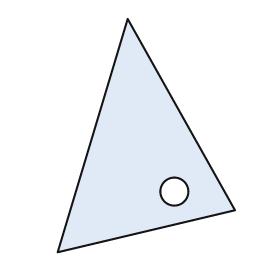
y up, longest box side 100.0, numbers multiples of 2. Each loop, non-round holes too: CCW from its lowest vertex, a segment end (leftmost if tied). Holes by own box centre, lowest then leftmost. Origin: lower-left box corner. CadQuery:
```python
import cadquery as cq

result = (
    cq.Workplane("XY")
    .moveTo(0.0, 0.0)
    .lineTo(76.0, 18.0)
    .lineTo(30.0, 100.0)
    .close()
    .moveTo(50.0, 26.0)
    .circle(6.0)
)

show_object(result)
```